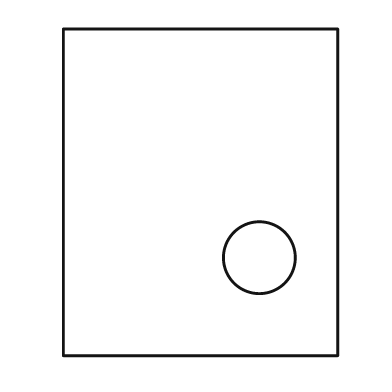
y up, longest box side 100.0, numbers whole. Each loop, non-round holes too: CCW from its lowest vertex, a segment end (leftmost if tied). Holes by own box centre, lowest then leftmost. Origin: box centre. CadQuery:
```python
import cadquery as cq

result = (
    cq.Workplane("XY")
    .moveTo(-42.0, -50.0)
    .lineTo(42.0, -50.0)
    .lineTo(42.0, 50.0)
    .lineTo(-42.0, 50.0)
    .close()
    .moveTo(18.0, -20.0)
    .circle(11.0)
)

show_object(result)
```